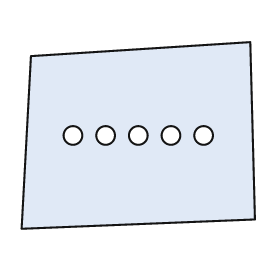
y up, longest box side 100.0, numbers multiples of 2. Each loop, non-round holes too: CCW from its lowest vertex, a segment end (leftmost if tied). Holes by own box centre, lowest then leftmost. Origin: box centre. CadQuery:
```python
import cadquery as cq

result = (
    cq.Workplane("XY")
    .moveTo(-50.0, -40.0)
    .lineTo(50.0, -36.0)
    .lineTo(48.0, 40.0)
    .lineTo(-46.0, 34.0)
    .close()
    .moveTo(-28.0, 0.0)
    .circle(4.0)
    .moveTo(-14.0, 0.0)
    .circle(4.0)
    .moveTo(0.0, 0.0)
    .circle(4.0)
    .moveTo(14.0, 0.0)
    .circle(4.0)
    .moveTo(28.0, 0.0)
    .circle(4.0)
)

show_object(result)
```